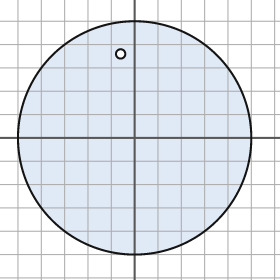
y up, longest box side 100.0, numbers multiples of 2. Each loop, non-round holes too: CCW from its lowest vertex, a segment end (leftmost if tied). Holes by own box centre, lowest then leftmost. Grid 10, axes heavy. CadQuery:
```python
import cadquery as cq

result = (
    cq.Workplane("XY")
    .moveTo(0.0, 0.0)
    .circle(50.0)
    .moveTo(-6.0, 36.0)
    .circle(2.0)
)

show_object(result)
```